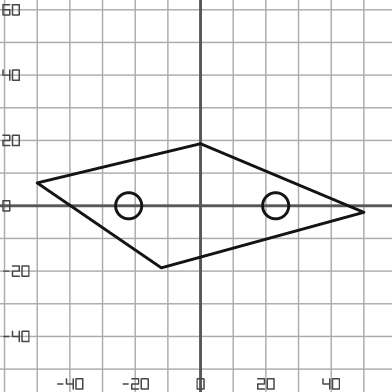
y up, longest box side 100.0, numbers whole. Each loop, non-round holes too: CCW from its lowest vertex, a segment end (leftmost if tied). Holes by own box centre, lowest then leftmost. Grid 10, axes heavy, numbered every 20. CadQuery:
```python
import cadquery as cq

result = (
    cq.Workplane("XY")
    .moveTo(-12.0, -19.0)
    .lineTo(50.0, -2.0)
    .lineTo(0.0, 19.0)
    .lineTo(-50.0, 7.0)
    .close()
    .moveTo(-22.0, 0.0)
    .circle(4.0)
    .moveTo(23.0, 0.0)
    .circle(4.0)
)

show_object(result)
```